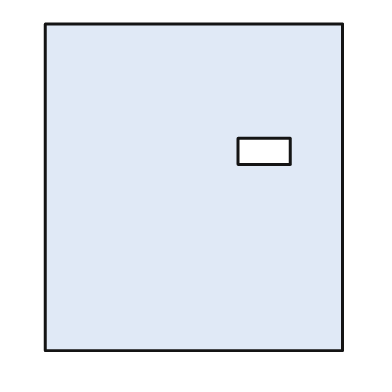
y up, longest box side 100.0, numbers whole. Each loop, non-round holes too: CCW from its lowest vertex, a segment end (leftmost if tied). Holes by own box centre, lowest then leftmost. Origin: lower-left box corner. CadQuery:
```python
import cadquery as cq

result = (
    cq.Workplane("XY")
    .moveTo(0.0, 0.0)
    .lineTo(91.0, 0.0)
    .lineTo(91.0, 100.0)
    .lineTo(0.0, 100.0)
    .close()
    .moveTo(59.0, 57.0)
    .lineTo(75.0, 57.0)
    .lineTo(75.0, 65.0)
    .lineTo(59.0, 65.0)
    .close()
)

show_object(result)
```